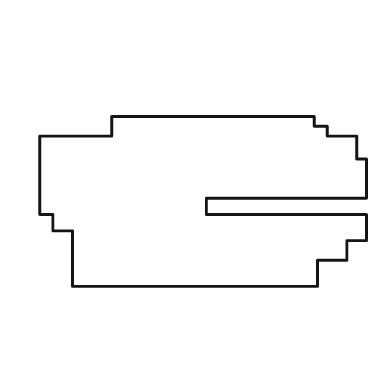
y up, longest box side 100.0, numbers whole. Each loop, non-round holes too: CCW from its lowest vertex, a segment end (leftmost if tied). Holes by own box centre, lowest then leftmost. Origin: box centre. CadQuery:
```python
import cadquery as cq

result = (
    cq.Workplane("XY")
    .moveTo(-40.0, -26.0)
    .lineTo(35.0, -26.0)
    .lineTo(35.0, -18.0)
    .lineTo(44.0, -18.0)
    .lineTo(44.0, -12.0)
    .lineTo(50.0, -12.0)
    .lineTo(50.0, -4.0)
    .lineTo(1.0, -4.0)
    .lineTo(1.0, 1.0)
    .lineTo(50.0, 1.0)
    .lineTo(50.0, 13.0)
    .lineTo(47.0, 13.0)
    .lineTo(47.0, 20.0)
    .lineTo(38.0, 20.0)
    .lineTo(38.0, 23.0)
    .lineTo(34.0, 23.0)
    .lineTo(34.0, 26.0)
    .lineTo(-28.0, 26.0)
    .lineTo(-28.0, 20.0)
    .lineTo(-50.0, 20.0)
    .lineTo(-50.0, -4.0)
    .lineTo(-46.0, -4.0)
    .lineTo(-46.0, -9.0)
    .lineTo(-40.0, -9.0)
    .close()
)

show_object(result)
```